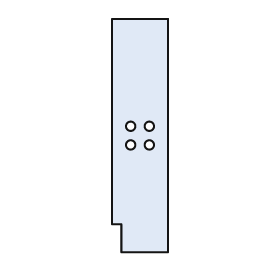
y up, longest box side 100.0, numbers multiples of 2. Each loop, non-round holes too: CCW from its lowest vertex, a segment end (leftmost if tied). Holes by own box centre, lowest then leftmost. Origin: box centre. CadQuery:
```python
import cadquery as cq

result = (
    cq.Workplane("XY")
    .moveTo(-8.0, -50.0)
    .lineTo(12.0, -50.0)
    .lineTo(12.0, 50.0)
    .lineTo(-12.0, 50.0)
    .lineTo(-12.0, -38.0)
    .lineTo(-8.0, -38.0)
    .close()
    .moveTo(-4.0, -4.0)
    .circle(2.0)
    .moveTo(4.0, -4.0)
    .circle(2.0)
    .moveTo(-4.0, 4.0)
    .circle(2.0)
    .moveTo(4.0, 4.0)
    .circle(2.0)
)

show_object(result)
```